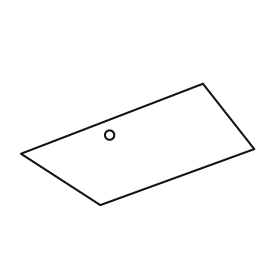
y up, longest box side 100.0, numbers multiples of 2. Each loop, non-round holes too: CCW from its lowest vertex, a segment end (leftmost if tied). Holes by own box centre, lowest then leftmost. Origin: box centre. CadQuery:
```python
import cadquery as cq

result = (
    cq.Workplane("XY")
    .moveTo(-16.0, -26.0)
    .lineTo(50.0, -2.0)
    .lineTo(28.0, 26.0)
    .lineTo(-50.0, -4.0)
    .close()
    .moveTo(-12.0, 4.0)
    .circle(2.0)
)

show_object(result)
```